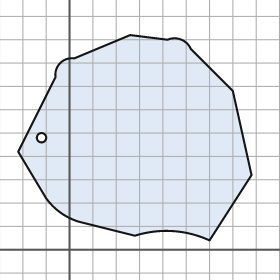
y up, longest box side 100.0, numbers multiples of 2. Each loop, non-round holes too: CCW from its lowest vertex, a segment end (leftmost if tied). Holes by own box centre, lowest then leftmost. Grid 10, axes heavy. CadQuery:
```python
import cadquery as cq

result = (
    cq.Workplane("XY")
    .moveTo(60.0, 4.0)
    .lineTo(78.0, 32.0)
    .lineTo(70.0, 68.0)
    .lineTo(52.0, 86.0)
    .threePointArc((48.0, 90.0), (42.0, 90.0))
    .lineTo(26.0, 92.0)
    .lineTo(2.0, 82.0)
    .threePointArc((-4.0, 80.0), (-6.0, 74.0))
    .lineTo(-22.0, 42.0)
    .lineTo(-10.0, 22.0)
    .threePointArc((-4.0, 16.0), (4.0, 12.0))
    .lineTo(28.0, 6.0)
    .threePointArc((44.0, 8.0), (60.0, 4.0))
    .close()
    .moveTo(-12.0, 48.0)
    .circle(2.0)
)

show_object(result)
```